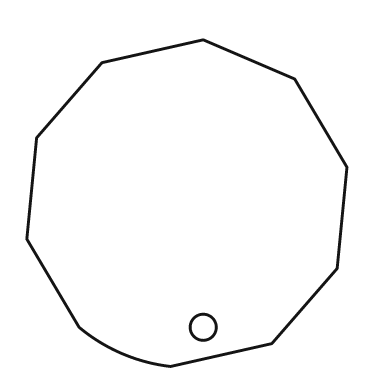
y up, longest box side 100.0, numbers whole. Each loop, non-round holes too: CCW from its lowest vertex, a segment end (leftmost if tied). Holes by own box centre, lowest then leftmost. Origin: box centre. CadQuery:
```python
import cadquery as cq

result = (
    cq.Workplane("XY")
    .moveTo(-5.0, -50.0)
    .lineTo(26.0, -43.0)
    .lineTo(46.0, -20.0)
    .lineTo(49.0, 11.0)
    .lineTo(33.0, 38.0)
    .lineTo(5.0, 50.0)
    .lineTo(-26.0, 43.0)
    .lineTo(-46.0, 20.0)
    .lineTo(-49.0, -11.0)
    .lineTo(-33.0, -38.0)
    .threePointArc((-20.0, -46.0), (-5.0, -50.0))
    .close()
    .moveTo(5.0, -38.0)
    .circle(4.0)
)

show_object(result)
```